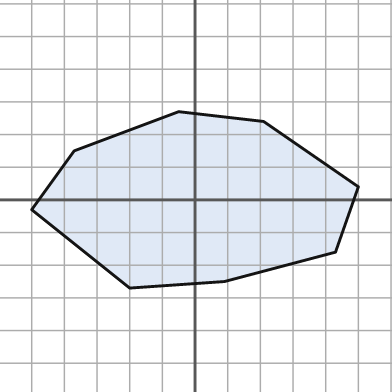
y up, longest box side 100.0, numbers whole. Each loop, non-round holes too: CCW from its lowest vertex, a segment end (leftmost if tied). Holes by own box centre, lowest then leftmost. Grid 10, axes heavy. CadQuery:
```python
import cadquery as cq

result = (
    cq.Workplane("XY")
    .moveTo(-20.0, -27.0)
    .lineTo(9.0, -25.0)
    .lineTo(43.0, -16.0)
    .lineTo(50.0, 4.0)
    .lineTo(21.0, 24.0)
    .lineTo(-5.0, 27.0)
    .lineTo(-37.0, 15.0)
    .lineTo(-50.0, -3.0)
    .close()
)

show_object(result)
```